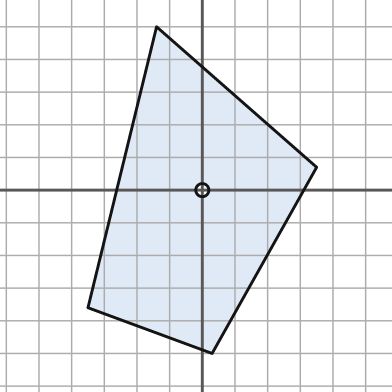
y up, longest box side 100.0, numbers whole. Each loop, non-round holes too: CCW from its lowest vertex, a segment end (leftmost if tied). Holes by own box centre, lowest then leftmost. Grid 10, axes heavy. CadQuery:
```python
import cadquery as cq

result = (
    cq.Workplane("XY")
    .moveTo(3.0, -50.0)
    .lineTo(35.0, 7.0)
    .lineTo(-14.0, 50.0)
    .lineTo(-35.0, -36.0)
    .close()
    .moveTo(0.0, 0.0)
    .circle(2.0)
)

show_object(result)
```